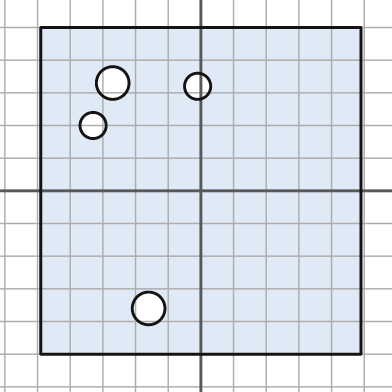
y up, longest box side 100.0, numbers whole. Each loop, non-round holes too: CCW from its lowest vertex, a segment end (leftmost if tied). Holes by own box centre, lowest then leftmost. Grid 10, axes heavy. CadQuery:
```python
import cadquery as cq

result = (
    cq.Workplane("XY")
    .moveTo(-49.0, -50.0)
    .lineTo(49.0, -50.0)
    .lineTo(49.0, 50.0)
    .lineTo(-49.0, 50.0)
    .close()
    .moveTo(-16.0, -36.0)
    .circle(5.0)
    .moveTo(-33.0, 20.0)
    .circle(4.0)
    .moveTo(-1.0, 32.0)
    .circle(4.0)
    .moveTo(-27.0, 33.0)
    .circle(5.0)
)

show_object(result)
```